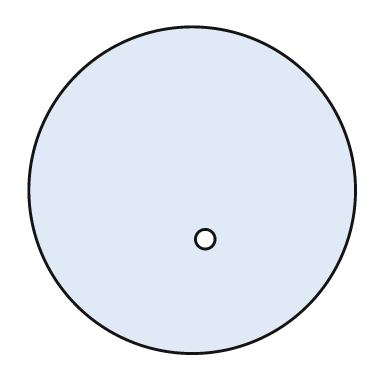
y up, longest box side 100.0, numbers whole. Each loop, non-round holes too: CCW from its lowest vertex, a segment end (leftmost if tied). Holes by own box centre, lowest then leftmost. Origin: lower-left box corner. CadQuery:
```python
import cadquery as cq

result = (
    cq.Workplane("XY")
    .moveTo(50.0, 50.0)
    .circle(50.0)
    .moveTo(54.0, 35.0)
    .circle(3.0)
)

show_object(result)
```